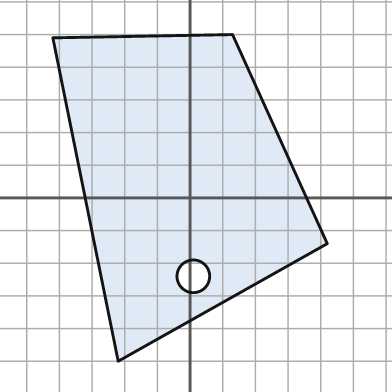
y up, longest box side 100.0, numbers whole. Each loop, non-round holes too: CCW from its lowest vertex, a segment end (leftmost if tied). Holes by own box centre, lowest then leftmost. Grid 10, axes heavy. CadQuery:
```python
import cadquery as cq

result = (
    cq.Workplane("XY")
    .moveTo(-22.0, -50.0)
    .lineTo(42.0, -14.0)
    .lineTo(13.0, 50.0)
    .lineTo(-42.0, 49.0)
    .close()
    .moveTo(1.0, -24.0)
    .circle(5.0)
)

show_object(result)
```